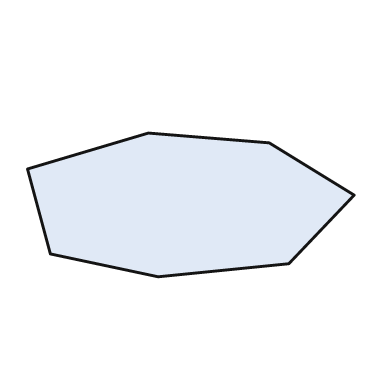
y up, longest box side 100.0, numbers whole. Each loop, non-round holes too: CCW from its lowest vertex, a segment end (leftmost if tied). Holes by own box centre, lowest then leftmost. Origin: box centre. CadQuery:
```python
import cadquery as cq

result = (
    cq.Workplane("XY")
    .moveTo(-10.0, -22.0)
    .lineTo(30.0, -18.0)
    .lineTo(50.0, 3.0)
    .lineTo(24.0, 19.0)
    .lineTo(-13.0, 22.0)
    .lineTo(-50.0, 11.0)
    .lineTo(-43.0, -15.0)
    .close()
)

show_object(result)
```